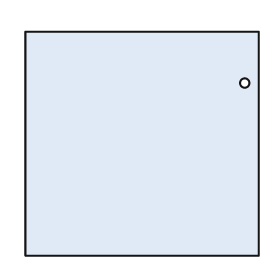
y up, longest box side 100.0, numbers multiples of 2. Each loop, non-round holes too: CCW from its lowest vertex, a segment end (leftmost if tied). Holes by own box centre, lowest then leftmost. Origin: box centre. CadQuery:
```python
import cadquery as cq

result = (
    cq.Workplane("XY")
    .moveTo(-50.0, -48.0)
    .lineTo(50.0, -48.0)
    .lineTo(50.0, 48.0)
    .lineTo(-50.0, 48.0)
    .close()
    .moveTo(44.0, 26.0)
    .circle(2.0)
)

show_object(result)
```